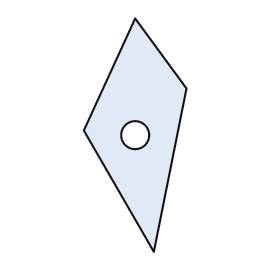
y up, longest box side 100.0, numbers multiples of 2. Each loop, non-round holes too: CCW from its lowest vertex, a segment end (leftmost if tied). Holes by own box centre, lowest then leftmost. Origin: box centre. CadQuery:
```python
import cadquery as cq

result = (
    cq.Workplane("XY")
    .moveTo(8.0, -50.0)
    .lineTo(22.0, 20.0)
    .lineTo(0.0, 50.0)
    .lineTo(-22.0, 2.0)
    .close()
    .moveTo(0.0, 0.0)
    .circle(6.0)
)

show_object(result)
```